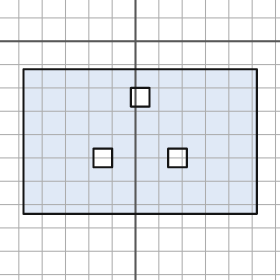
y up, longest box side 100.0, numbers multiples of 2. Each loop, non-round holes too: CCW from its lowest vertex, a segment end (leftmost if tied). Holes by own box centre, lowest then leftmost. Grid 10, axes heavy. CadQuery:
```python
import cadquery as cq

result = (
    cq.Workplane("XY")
    .moveTo(-48.0, -74.0)
    .lineTo(52.0, -74.0)
    .lineTo(52.0, -12.0)
    .lineTo(-48.0, -12.0)
    .close()
    .moveTo(-18.0, -54.0)
    .lineTo(-10.0, -54.0)
    .lineTo(-10.0, -46.0)
    .lineTo(-18.0, -46.0)
    .close()
    .moveTo(14.0, -54.0)
    .lineTo(22.0, -54.0)
    .lineTo(22.0, -46.0)
    .lineTo(14.0, -46.0)
    .close()
    .moveTo(-2.0, -28.0)
    .lineTo(6.0, -28.0)
    .lineTo(6.0, -20.0)
    .lineTo(-2.0, -20.0)
    .close()
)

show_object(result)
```